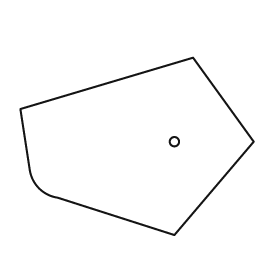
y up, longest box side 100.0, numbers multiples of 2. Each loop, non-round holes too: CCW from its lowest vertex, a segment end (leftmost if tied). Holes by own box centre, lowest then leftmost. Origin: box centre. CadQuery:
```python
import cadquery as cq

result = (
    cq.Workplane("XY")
    .moveTo(16.0, -38.0)
    .lineTo(50.0, 2.0)
    .lineTo(24.0, 38.0)
    .lineTo(-50.0, 16.0)
    .lineTo(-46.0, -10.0)
    .threePointArc((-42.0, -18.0), (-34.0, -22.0))
    .close()
    .moveTo(16.0, 2.0)
    .circle(2.0)
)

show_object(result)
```